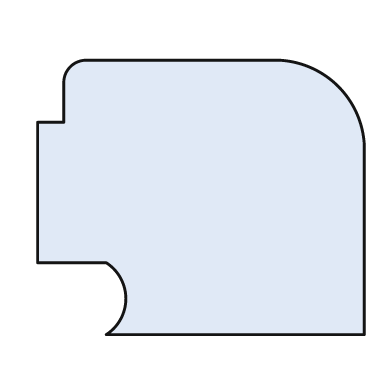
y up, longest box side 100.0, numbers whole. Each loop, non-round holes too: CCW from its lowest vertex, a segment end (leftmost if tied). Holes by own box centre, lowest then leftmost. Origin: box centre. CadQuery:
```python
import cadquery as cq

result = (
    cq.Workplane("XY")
    .moveTo(-29.0, -42.0)
    .lineTo(50.0, -42.0)
    .lineTo(50.0, 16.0)
    .threePointArc((42.0, 34.0), (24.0, 42.0))
    .lineTo(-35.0, 42.0)
    .threePointArc((-40.0, 40.0), (-42.0, 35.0))
    .lineTo(-42.0, 23.0)
    .lineTo(-50.0, 23.0)
    .lineTo(-50.0, -20.0)
    .lineTo(-29.0, -20.0)
    .threePointArc((-23.0, -31.0), (-29.0, -42.0))
    .close()
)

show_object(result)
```